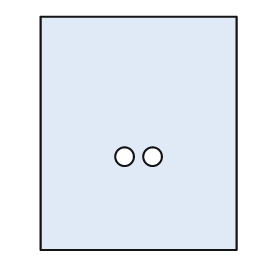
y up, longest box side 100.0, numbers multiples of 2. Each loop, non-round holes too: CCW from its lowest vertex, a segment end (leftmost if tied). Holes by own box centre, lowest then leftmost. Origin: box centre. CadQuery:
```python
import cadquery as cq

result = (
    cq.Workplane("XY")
    .moveTo(-42.0, -50.0)
    .lineTo(42.0, -50.0)
    .lineTo(42.0, 50.0)
    .lineTo(-42.0, 50.0)
    .close()
    .moveTo(-6.0, -10.0)
    .circle(4.0)
    .moveTo(6.0, -10.0)
    .circle(4.0)
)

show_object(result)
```